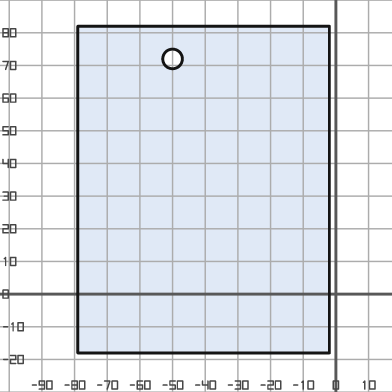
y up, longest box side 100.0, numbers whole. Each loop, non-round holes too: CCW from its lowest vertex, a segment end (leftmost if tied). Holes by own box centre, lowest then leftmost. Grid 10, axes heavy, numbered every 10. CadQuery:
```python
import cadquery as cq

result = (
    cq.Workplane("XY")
    .moveTo(-79.0, -18.0)
    .lineTo(-2.0, -18.0)
    .lineTo(-2.0, 82.0)
    .lineTo(-79.0, 82.0)
    .close()
    .moveTo(-50.0, 72.0)
    .circle(3.0)
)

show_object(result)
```